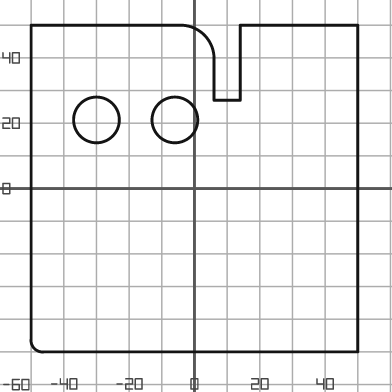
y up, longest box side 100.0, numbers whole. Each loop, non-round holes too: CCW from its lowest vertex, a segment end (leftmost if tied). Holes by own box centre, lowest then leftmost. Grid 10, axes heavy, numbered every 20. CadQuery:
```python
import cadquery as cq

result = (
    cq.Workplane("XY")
    .moveTo(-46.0, -50.0)
    .lineTo(50.0, -50.0)
    .lineTo(50.0, 50.0)
    .lineTo(14.0, 50.0)
    .lineTo(14.0, 27.0)
    .lineTo(6.0, 27.0)
    .lineTo(6.0, 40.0)
    .threePointArc((3.0, 47.0), (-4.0, 50.0))
    .lineTo(-50.0, 50.0)
    .lineTo(-50.0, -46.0)
    .threePointArc((-49.0, -49.0), (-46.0, -50.0))
    .close()
    .moveTo(-30.0, 21.0)
    .circle(7.0)
    .moveTo(-6.0, 21.0)
    .circle(7.0)
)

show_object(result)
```